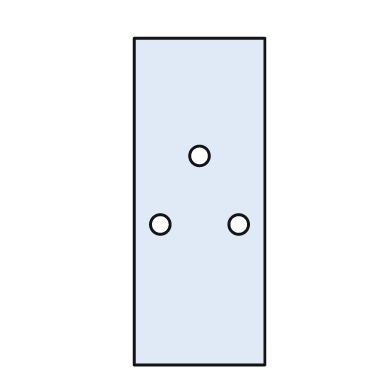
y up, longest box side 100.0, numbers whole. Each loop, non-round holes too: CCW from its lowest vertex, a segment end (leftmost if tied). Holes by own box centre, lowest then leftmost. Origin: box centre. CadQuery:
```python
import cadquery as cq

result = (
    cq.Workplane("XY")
    .moveTo(-20.0, -50.0)
    .lineTo(20.0, -50.0)
    .lineTo(20.0, 50.0)
    .lineTo(-20.0, 50.0)
    .close()
    .moveTo(-12.0, -7.0)
    .circle(3.0)
    .moveTo(12.0, -7.0)
    .circle(3.0)
    .moveTo(0.0, 14.0)
    .circle(3.0)
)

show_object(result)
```